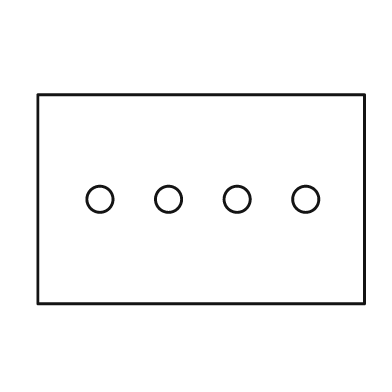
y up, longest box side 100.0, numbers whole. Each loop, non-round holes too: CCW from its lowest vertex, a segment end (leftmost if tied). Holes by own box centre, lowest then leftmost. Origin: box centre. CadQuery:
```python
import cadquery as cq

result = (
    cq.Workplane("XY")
    .moveTo(-50.0, -32.0)
    .lineTo(50.0, -32.0)
    .lineTo(50.0, 32.0)
    .lineTo(-50.0, 32.0)
    .close()
    .moveTo(-31.0, 0.0)
    .circle(4.0)
    .moveTo(-10.0, 0.0)
    .circle(4.0)
    .moveTo(11.0, 0.0)
    .circle(4.0)
    .moveTo(32.0, 0.0)
    .circle(4.0)
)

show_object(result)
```